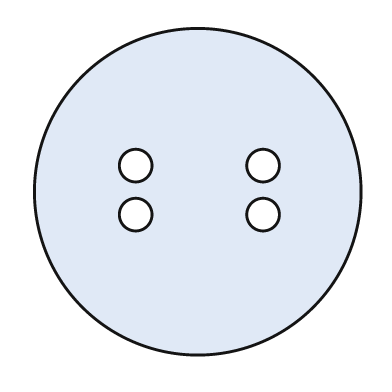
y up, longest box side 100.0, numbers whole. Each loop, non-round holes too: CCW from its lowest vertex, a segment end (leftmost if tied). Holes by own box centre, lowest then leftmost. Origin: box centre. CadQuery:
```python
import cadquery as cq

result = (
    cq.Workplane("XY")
    .moveTo(0.0, 0.0)
    .circle(50.0)
    .moveTo(-19.0, -7.0)
    .circle(5.0)
    .moveTo(20.0, -7.0)
    .circle(5.0)
    .moveTo(-19.0, 8.0)
    .circle(5.0)
    .moveTo(20.0, 8.0)
    .circle(5.0)
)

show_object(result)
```